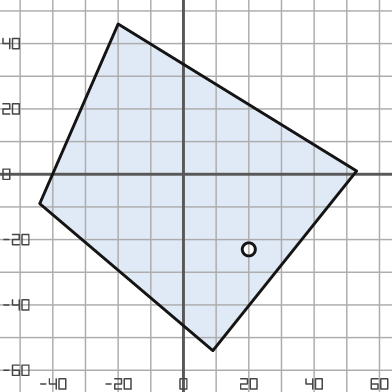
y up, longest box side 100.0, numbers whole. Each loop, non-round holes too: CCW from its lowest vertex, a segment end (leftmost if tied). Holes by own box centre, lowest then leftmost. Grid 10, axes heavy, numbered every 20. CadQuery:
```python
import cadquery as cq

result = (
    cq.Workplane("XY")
    .moveTo(9.0, -54.0)
    .lineTo(53.0, 1.0)
    .lineTo(-20.0, 46.0)
    .lineTo(-44.0, -9.0)
    .close()
    .moveTo(20.0, -23.0)
    .circle(2.0)
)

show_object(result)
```